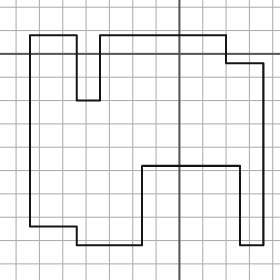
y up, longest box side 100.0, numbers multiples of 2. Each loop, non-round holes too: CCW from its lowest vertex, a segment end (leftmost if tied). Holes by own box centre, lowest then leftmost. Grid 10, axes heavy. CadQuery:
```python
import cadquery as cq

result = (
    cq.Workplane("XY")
    .moveTo(-44.0, -82.0)
    .lineTo(-16.0, -82.0)
    .lineTo(-16.0, -48.0)
    .lineTo(26.0, -48.0)
    .lineTo(26.0, -82.0)
    .lineTo(36.0, -82.0)
    .lineTo(36.0, -4.0)
    .lineTo(20.0, -4.0)
    .lineTo(20.0, 8.0)
    .lineTo(-34.0, 8.0)
    .lineTo(-34.0, -20.0)
    .lineTo(-44.0, -20.0)
    .lineTo(-44.0, 8.0)
    .lineTo(-64.0, 8.0)
    .lineTo(-64.0, -74.0)
    .lineTo(-44.0, -74.0)
    .close()
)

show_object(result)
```